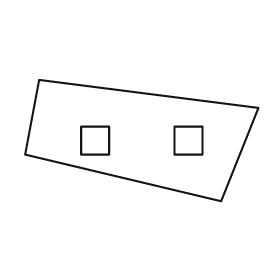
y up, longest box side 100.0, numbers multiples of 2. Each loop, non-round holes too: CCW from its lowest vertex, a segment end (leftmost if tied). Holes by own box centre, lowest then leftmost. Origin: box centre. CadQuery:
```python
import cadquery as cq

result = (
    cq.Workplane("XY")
    .moveTo(34.0, -26.0)
    .lineTo(50.0, 14.0)
    .lineTo(-44.0, 26.0)
    .lineTo(-50.0, -6.0)
    .close()
    .moveTo(-26.0, -6.0)
    .lineTo(-14.0, -6.0)
    .lineTo(-14.0, 6.0)
    .lineTo(-26.0, 6.0)
    .close()
    .moveTo(14.0, -6.0)
    .lineTo(26.0, -6.0)
    .lineTo(26.0, 6.0)
    .lineTo(14.0, 6.0)
    .close()
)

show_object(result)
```